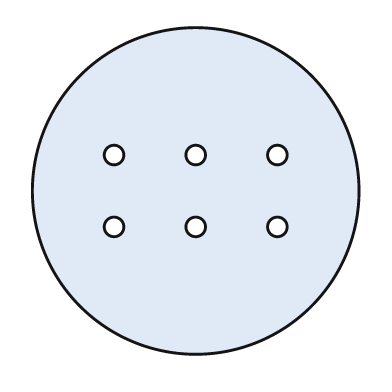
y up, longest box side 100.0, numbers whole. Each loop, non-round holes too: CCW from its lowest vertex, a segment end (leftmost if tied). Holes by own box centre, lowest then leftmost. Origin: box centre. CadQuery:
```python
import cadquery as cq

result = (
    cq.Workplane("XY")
    .moveTo(0.0, 0.0)
    .circle(50.0)
    .moveTo(-25.0, -11.0)
    .circle(3.0)
    .moveTo(0.0, -11.0)
    .circle(3.0)
    .moveTo(25.0, -11.0)
    .circle(3.0)
    .moveTo(-25.0, 11.0)
    .circle(3.0)
    .moveTo(0.0, 11.0)
    .circle(3.0)
    .moveTo(25.0, 11.0)
    .circle(3.0)
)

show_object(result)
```